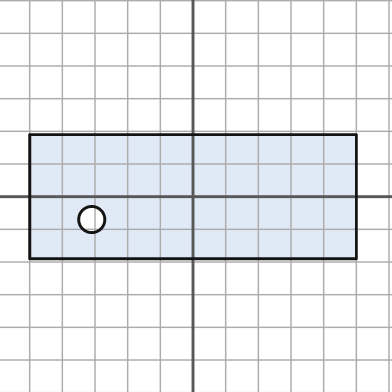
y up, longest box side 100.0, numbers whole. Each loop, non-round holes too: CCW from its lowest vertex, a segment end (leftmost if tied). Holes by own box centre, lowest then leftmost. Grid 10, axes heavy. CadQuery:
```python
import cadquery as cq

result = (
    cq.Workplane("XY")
    .moveTo(-50.0, -19.0)
    .lineTo(50.0, -19.0)
    .lineTo(50.0, 19.0)
    .lineTo(-50.0, 19.0)
    .close()
    .moveTo(-31.0, -7.0)
    .circle(4.0)
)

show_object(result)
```